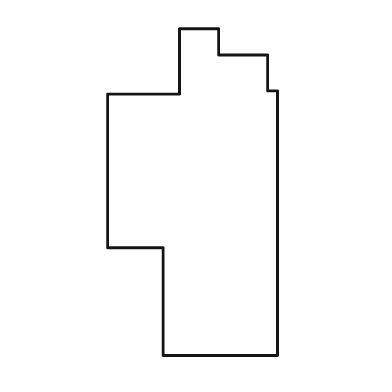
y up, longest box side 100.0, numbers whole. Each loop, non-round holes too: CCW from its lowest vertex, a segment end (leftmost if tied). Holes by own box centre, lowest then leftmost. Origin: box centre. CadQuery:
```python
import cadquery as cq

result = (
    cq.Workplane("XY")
    .moveTo(-9.0, -50.0)
    .lineTo(26.0, -50.0)
    .lineTo(26.0, 31.0)
    .lineTo(23.0, 31.0)
    .lineTo(23.0, 42.0)
    .lineTo(8.0, 42.0)
    .lineTo(8.0, 50.0)
    .lineTo(-4.0, 50.0)
    .lineTo(-4.0, 30.0)
    .lineTo(-26.0, 30.0)
    .lineTo(-26.0, -17.0)
    .lineTo(-9.0, -17.0)
    .close()
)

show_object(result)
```